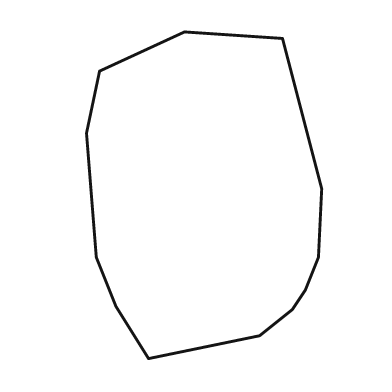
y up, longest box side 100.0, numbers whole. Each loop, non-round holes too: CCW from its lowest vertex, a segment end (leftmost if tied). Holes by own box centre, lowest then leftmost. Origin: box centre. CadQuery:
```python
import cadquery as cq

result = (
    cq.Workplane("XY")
    .moveTo(-17.0, -50.0)
    .lineTo(17.0, -43.0)
    .lineTo(27.0, -35.0)
    .lineTo(31.0, -29.0)
    .lineTo(35.0, -19.0)
    .lineTo(36.0, 2.0)
    .lineTo(24.0, 48.0)
    .lineTo(-6.0, 50.0)
    .lineTo(-32.0, 38.0)
    .lineTo(-36.0, 19.0)
    .lineTo(-33.0, -19.0)
    .lineTo(-27.0, -34.0)
    .close()
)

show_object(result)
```